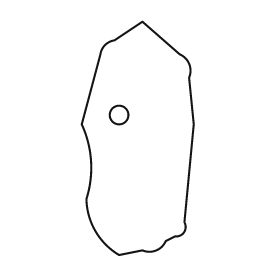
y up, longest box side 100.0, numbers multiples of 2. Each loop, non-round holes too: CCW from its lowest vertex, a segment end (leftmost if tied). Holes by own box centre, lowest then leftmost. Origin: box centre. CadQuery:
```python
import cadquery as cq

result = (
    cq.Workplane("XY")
    .moveTo(-8.0, -50.0)
    .lineTo(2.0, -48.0)
    .threePointArc((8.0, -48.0), (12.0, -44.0))
    .lineTo(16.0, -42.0)
    .threePointArc((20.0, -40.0), (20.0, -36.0))
    .lineTo(24.0, 6.0)
    .lineTo(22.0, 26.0)
    .threePointArc((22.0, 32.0), (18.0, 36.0))
    .lineTo(2.0, 50.0)
    .lineTo(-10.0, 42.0)
    .threePointArc((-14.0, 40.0), (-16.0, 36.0))
    .lineTo(-24.0, 6.0)
    .threePointArc((-20.0, -10.0), (-22.0, -26.0))
    .threePointArc((-18.0, -40.0), (-8.0, -50.0))
    .close()
    .moveTo(-8.0, 10.0)
    .circle(4.0)
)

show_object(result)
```